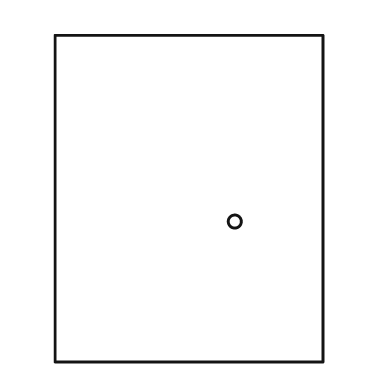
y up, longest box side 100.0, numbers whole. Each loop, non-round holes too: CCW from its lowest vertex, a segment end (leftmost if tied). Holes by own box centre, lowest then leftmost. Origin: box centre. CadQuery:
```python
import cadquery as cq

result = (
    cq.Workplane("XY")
    .moveTo(-41.0, -50.0)
    .lineTo(41.0, -50.0)
    .lineTo(41.0, 50.0)
    .lineTo(-41.0, 50.0)
    .close()
    .moveTo(14.0, -7.0)
    .circle(2.0)
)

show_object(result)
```